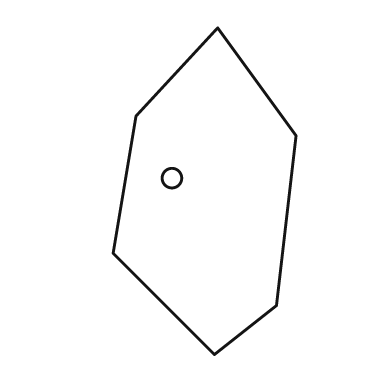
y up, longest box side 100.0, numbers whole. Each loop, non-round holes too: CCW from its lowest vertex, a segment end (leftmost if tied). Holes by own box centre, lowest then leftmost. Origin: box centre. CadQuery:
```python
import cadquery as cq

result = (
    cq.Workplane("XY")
    .moveTo(3.0, -50.0)
    .lineTo(22.0, -35.0)
    .lineTo(28.0, 17.0)
    .lineTo(4.0, 50.0)
    .lineTo(-21.0, 23.0)
    .lineTo(-28.0, -19.0)
    .close()
    .moveTo(-10.0, 4.0)
    .circle(3.0)
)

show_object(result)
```